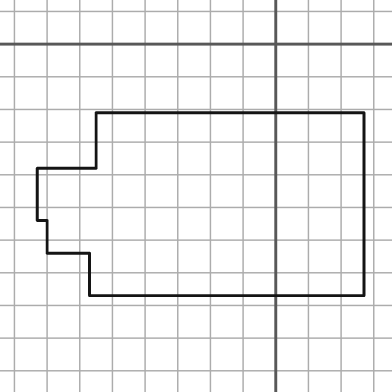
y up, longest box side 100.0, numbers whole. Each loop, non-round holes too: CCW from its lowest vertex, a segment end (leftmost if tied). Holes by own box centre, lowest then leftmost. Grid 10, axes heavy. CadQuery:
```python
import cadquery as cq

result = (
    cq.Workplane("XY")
    .moveTo(-57.0, -77.0)
    .lineTo(27.0, -77.0)
    .lineTo(27.0, -21.0)
    .lineTo(-55.0, -21.0)
    .lineTo(-55.0, -38.0)
    .lineTo(-73.0, -38.0)
    .lineTo(-73.0, -54.0)
    .lineTo(-70.0, -54.0)
    .lineTo(-70.0, -64.0)
    .lineTo(-57.0, -64.0)
    .close()
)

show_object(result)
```